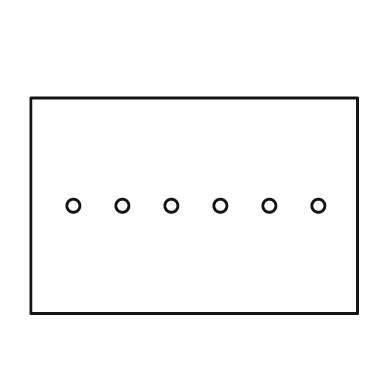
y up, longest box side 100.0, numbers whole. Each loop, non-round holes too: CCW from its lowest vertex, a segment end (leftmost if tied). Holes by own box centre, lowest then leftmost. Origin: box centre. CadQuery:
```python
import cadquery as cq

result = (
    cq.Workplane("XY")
    .moveTo(-50.0, -33.0)
    .lineTo(50.0, -33.0)
    .lineTo(50.0, 33.0)
    .lineTo(-50.0, 33.0)
    .close()
    .moveTo(-37.0, 0.0)
    .circle(2.0)
    .moveTo(-22.0, 0.0)
    .circle(2.0)
    .moveTo(-7.0, 0.0)
    .circle(2.0)
    .moveTo(8.0, 0.0)
    .circle(2.0)
    .moveTo(23.0, 0.0)
    .circle(2.0)
    .moveTo(38.0, 0.0)
    .circle(2.0)
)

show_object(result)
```